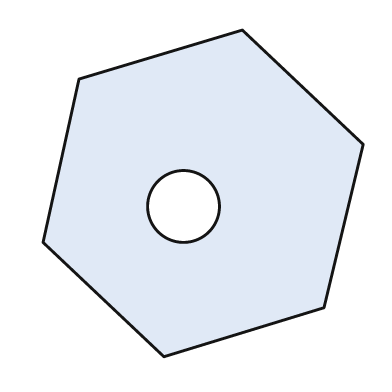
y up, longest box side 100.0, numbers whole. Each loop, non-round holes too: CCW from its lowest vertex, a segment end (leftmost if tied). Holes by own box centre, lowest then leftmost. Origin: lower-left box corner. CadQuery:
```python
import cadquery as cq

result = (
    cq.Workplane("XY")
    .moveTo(37.0, 0.0)
    .lineTo(86.0, 15.0)
    .lineTo(98.0, 65.0)
    .lineTo(61.0, 100.0)
    .lineTo(11.0, 85.0)
    .lineTo(0.0, 35.0)
    .close()
    .moveTo(43.0, 46.0)
    .circle(11.0)
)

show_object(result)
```